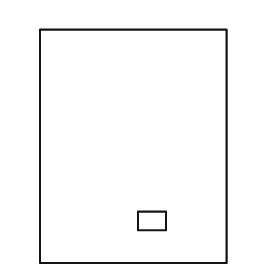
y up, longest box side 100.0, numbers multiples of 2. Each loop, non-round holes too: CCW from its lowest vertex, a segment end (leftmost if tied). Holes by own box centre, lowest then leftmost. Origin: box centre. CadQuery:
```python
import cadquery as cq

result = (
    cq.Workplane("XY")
    .moveTo(-40.0, -50.0)
    .lineTo(40.0, -50.0)
    .lineTo(40.0, 50.0)
    .lineTo(-40.0, 50.0)
    .close()
    .moveTo(2.0, -36.0)
    .lineTo(14.0, -36.0)
    .lineTo(14.0, -28.0)
    .lineTo(2.0, -28.0)
    .close()
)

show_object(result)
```